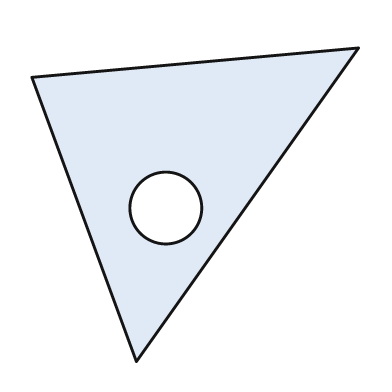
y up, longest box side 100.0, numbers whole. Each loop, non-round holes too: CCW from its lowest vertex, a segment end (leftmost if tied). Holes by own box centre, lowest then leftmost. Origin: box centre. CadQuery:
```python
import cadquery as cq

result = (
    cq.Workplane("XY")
    .moveTo(-18.0, -48.0)
    .lineTo(50.0, 48.0)
    .lineTo(-50.0, 39.0)
    .close()
    .moveTo(-9.0, -1.0)
    .circle(11.0)
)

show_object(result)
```